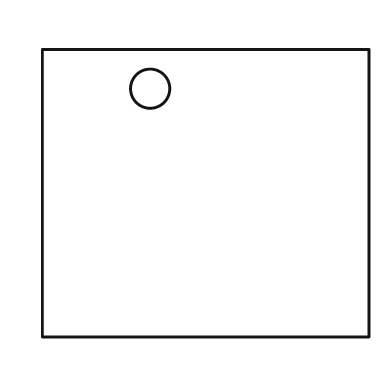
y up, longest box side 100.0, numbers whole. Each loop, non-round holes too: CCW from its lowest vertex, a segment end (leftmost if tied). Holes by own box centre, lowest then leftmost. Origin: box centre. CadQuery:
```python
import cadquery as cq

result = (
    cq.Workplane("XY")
    .moveTo(-50.0, -44.0)
    .lineTo(50.0, -44.0)
    .lineTo(50.0, 44.0)
    .lineTo(-50.0, 44.0)
    .close()
    .moveTo(-17.0, 32.0)
    .circle(6.0)
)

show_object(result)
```